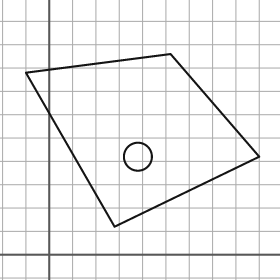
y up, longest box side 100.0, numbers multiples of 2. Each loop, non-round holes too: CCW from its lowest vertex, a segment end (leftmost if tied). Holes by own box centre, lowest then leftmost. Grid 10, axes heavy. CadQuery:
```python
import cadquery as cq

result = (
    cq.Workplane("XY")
    .moveTo(28.0, 12.0)
    .lineTo(90.0, 42.0)
    .lineTo(52.0, 86.0)
    .lineTo(-10.0, 78.0)
    .close()
    .moveTo(38.0, 42.0)
    .circle(6.0)
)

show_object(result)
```